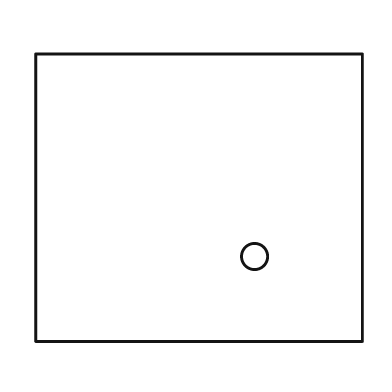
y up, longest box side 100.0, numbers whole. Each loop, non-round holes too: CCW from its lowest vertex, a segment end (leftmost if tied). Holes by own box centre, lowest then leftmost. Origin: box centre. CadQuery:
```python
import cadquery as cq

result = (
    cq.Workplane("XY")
    .moveTo(-50.0, -44.0)
    .lineTo(50.0, -44.0)
    .lineTo(50.0, 44.0)
    .lineTo(-50.0, 44.0)
    .close()
    .moveTo(17.0, -18.0)
    .circle(4.0)
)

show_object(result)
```